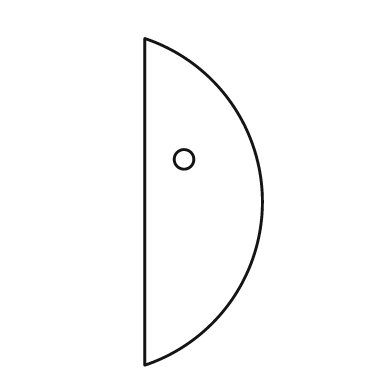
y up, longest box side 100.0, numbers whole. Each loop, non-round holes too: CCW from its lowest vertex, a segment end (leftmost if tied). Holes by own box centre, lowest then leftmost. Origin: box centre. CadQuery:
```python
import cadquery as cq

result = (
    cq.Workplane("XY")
    .moveTo(-18.0, -50.0)
    .threePointArc((18.0, 0.0), (-18.0, 50.0))
    .close()
    .moveTo(-6.0, 13.0)
    .circle(3.0)
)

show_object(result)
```